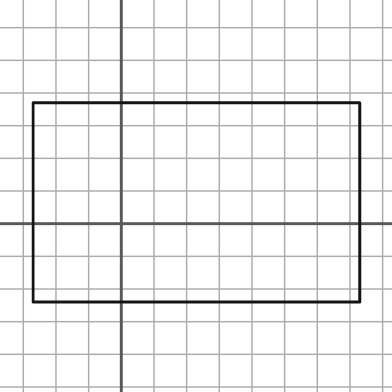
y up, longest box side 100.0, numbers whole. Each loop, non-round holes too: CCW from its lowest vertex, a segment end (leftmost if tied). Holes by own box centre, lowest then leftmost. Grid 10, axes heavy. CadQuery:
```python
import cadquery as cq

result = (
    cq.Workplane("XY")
    .moveTo(-27.0, -24.0)
    .lineTo(73.0, -24.0)
    .lineTo(73.0, 37.0)
    .lineTo(-27.0, 37.0)
    .close()
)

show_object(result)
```